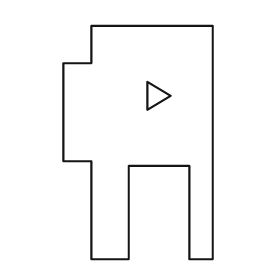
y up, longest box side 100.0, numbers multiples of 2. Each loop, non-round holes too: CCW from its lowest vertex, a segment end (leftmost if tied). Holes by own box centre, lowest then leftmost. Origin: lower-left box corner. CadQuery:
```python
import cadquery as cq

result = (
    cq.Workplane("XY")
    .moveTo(12.0, 0.0)
    .lineTo(28.0, 0.0)
    .lineTo(28.0, 40.0)
    .lineTo(54.0, 40.0)
    .lineTo(54.0, 0.0)
    .lineTo(64.0, 0.0)
    .lineTo(64.0, 100.0)
    .lineTo(12.0, 100.0)
    .lineTo(12.0, 84.0)
    .lineTo(0.0, 84.0)
    .lineTo(0.0, 42.0)
    .lineTo(12.0, 42.0)
    .close()
    .moveTo(36.0, 64.0)
    .lineTo(46.0, 70.0)
    .lineTo(36.0, 76.0)
    .close()
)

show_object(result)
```